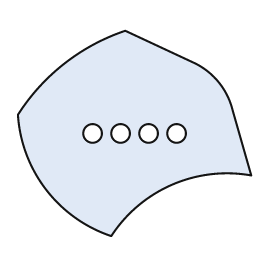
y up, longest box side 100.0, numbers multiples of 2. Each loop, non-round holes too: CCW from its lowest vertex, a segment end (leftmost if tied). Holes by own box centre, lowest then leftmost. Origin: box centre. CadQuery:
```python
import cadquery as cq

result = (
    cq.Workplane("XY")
    .moveTo(-10.0, -44.0)
    .threePointArc((16.0, -22.0), (50.0, -18.0))
    .lineTo(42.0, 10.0)
    .threePointArc((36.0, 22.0), (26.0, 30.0))
    .lineTo(-4.0, 44.0)
    .threePointArc((-30.0, 30.0), (-50.0, 8.0))
    .threePointArc((-38.0, -24.0), (-10.0, -44.0))
    .close()
    .moveTo(-18.0, 0.0)
    .circle(4.0)
    .moveTo(-6.0, 0.0)
    .circle(4.0)
    .moveTo(6.0, 0.0)
    .circle(4.0)
    .moveTo(18.0, 0.0)
    .circle(4.0)
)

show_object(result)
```